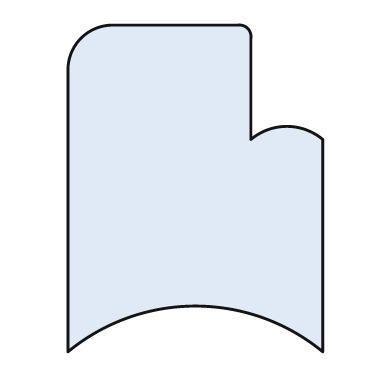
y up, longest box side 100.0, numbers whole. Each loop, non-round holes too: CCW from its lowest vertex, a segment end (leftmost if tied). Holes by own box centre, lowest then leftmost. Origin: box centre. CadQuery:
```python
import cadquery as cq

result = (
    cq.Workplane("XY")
    .moveTo(-39.0, -50.0)
    .threePointArc((0.0, -36.0), (39.0, -50.0))
    .lineTo(39.0, 15.0)
    .threePointArc((28.0, 19.0), (17.0, 15.0))
    .lineTo(17.0, 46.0)
    .threePointArc((16.0, 49.0), (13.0, 50.0))
    .lineTo(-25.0, 50.0)
    .threePointArc((-35.0, 46.0), (-39.0, 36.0))
    .close()
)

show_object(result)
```